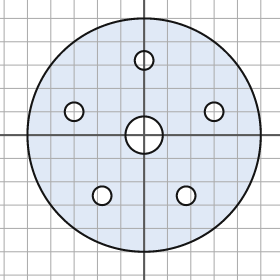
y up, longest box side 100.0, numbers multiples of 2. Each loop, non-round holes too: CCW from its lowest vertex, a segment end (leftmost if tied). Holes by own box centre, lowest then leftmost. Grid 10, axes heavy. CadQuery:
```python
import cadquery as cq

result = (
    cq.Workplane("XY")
    .moveTo(0.0, 0.0)
    .circle(50.0)
    .moveTo(-18.0, -26.0)
    .circle(4.0)
    .moveTo(18.0, -26.0)
    .circle(4.0)
    .moveTo(0.0, 0.0)
    .circle(8.0)
    .moveTo(-30.0, 10.0)
    .circle(4.0)
    .moveTo(30.0, 10.0)
    .circle(4.0)
    .moveTo(0.0, 32.0)
    .circle(4.0)
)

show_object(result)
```